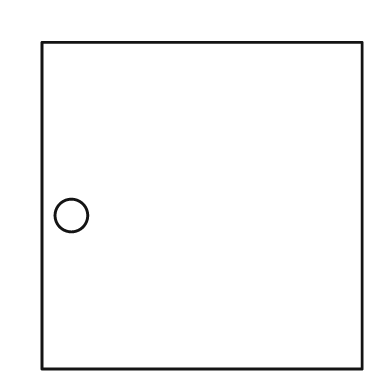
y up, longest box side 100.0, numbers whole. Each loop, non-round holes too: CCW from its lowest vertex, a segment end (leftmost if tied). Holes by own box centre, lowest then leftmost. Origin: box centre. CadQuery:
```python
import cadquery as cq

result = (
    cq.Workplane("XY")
    .moveTo(-49.0, -50.0)
    .lineTo(49.0, -50.0)
    .lineTo(49.0, 50.0)
    .lineTo(-49.0, 50.0)
    .close()
    .moveTo(-40.0, -3.0)
    .circle(5.0)
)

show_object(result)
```